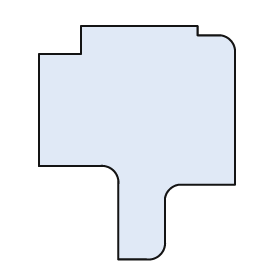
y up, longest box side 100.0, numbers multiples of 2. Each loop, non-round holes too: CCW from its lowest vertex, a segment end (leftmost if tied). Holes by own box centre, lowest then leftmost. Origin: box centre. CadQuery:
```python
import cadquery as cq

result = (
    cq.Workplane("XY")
    .moveTo(-8.0, -50.0)
    .lineTo(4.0, -50.0)
    .threePointArc((10.0, -48.0), (12.0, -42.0))
    .lineTo(12.0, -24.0)
    .threePointArc((14.0, -20.0), (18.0, -18.0))
    .lineTo(42.0, -18.0)
    .lineTo(42.0, 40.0)
    .threePointArc((40.0, 44.0), (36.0, 46.0))
    .lineTo(26.0, 46.0)
    .lineTo(26.0, 50.0)
    .lineTo(-24.0, 50.0)
    .lineTo(-24.0, 38.0)
    .lineTo(-42.0, 38.0)
    .lineTo(-42.0, -10.0)
    .lineTo(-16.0, -10.0)
    .threePointArc((-10.0, -12.0), (-8.0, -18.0))
    .close()
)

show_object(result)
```